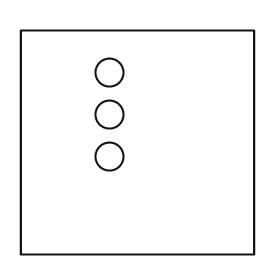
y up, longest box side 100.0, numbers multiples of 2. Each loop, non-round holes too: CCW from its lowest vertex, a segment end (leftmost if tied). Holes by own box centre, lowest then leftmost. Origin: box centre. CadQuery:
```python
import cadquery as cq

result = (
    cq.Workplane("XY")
    .moveTo(-50.0, -48.0)
    .lineTo(50.0, -48.0)
    .lineTo(50.0, 48.0)
    .lineTo(-50.0, 48.0)
    .close()
    .moveTo(-12.0, -6.0)
    .circle(6.0)
    .moveTo(-12.0, 12.0)
    .circle(6.0)
    .moveTo(-12.0, 30.0)
    .circle(6.0)
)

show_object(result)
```